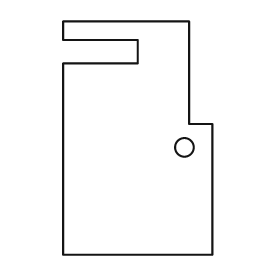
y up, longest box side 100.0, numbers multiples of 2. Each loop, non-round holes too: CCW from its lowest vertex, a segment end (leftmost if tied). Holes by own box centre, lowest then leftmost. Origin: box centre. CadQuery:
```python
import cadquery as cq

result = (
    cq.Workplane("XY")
    .moveTo(-32.0, -50.0)
    .lineTo(32.0, -50.0)
    .lineTo(32.0, 6.0)
    .lineTo(22.0, 6.0)
    .lineTo(22.0, 50.0)
    .lineTo(-32.0, 50.0)
    .lineTo(-32.0, 42.0)
    .lineTo(0.0, 42.0)
    .lineTo(0.0, 32.0)
    .lineTo(-32.0, 32.0)
    .close()
    .moveTo(20.0, -4.0)
    .circle(4.0)
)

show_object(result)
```